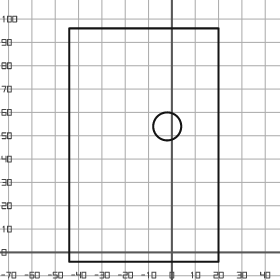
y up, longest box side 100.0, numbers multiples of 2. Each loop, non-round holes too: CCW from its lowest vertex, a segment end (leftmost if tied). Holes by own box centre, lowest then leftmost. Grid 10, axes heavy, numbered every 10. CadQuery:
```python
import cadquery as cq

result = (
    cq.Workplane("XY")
    .moveTo(-44.0, -4.0)
    .lineTo(20.0, -4.0)
    .lineTo(20.0, 96.0)
    .lineTo(-44.0, 96.0)
    .close()
    .moveTo(-2.0, 54.0)
    .circle(6.0)
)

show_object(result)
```